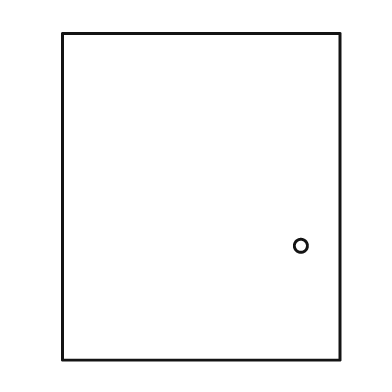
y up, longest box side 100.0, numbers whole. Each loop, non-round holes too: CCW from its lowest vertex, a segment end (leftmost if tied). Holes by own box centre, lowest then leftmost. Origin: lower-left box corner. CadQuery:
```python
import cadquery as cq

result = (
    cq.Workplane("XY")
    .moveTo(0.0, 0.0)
    .lineTo(85.0, 0.0)
    .lineTo(85.0, 100.0)
    .lineTo(0.0, 100.0)
    .close()
    .moveTo(73.0, 35.0)
    .circle(2.0)
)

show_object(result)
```